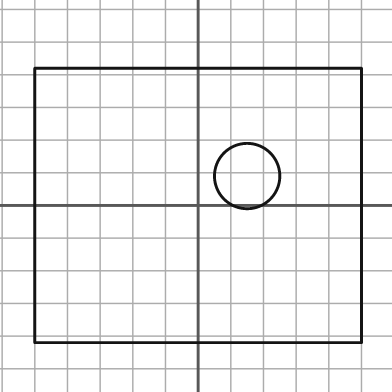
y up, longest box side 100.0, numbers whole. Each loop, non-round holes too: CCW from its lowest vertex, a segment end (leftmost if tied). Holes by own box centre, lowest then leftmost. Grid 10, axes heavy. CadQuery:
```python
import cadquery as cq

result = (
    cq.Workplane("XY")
    .moveTo(-50.0, -42.0)
    .lineTo(50.0, -42.0)
    .lineTo(50.0, 42.0)
    .lineTo(-50.0, 42.0)
    .close()
    .moveTo(15.0, 9.0)
    .circle(10.0)
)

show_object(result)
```